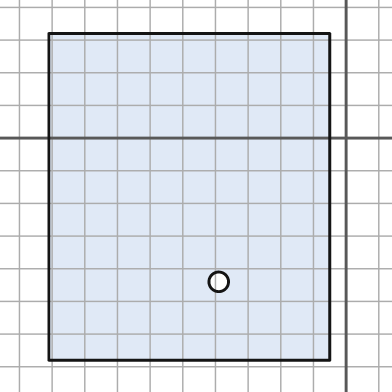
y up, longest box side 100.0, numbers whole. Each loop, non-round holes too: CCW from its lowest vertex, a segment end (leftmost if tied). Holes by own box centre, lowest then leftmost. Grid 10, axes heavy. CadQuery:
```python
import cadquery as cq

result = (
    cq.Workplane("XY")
    .moveTo(-91.0, -68.0)
    .lineTo(-5.0, -68.0)
    .lineTo(-5.0, 32.0)
    .lineTo(-91.0, 32.0)
    .close()
    .moveTo(-39.0, -44.0)
    .circle(3.0)
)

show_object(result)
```